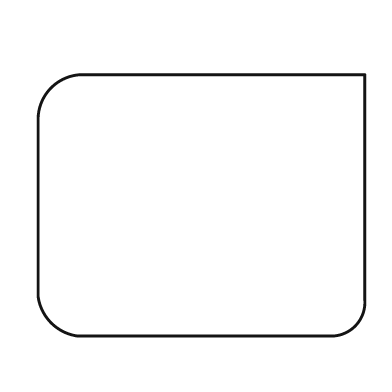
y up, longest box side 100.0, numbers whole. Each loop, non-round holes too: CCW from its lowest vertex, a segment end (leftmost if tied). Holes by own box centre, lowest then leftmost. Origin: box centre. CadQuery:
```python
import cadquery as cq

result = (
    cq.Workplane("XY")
    .moveTo(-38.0, -40.0)
    .lineTo(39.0, -40.0)
    .threePointArc((47.0, -37.0), (50.0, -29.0))
    .lineTo(50.0, 40.0)
    .lineTo(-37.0, 40.0)
    .threePointArc((-46.0, 36.0), (-50.0, 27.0))
    .lineTo(-50.0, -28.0)
    .threePointArc((-46.0, -36.0), (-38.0, -40.0))
    .close()
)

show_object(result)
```